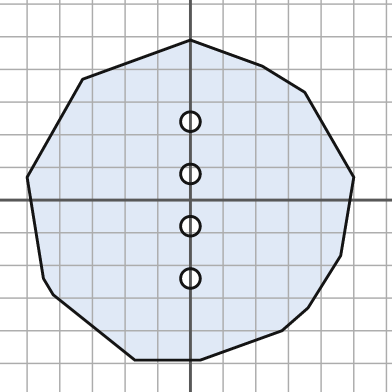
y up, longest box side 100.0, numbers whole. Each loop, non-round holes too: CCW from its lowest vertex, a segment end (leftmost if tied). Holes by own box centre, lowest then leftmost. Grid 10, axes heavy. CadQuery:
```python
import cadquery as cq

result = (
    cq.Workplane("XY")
    .moveTo(-17.0, -49.0)
    .lineTo(3.0, -49.0)
    .lineTo(28.0, -40.0)
    .lineTo(36.0, -33.0)
    .lineTo(46.0, -17.0)
    .lineTo(50.0, 7.0)
    .lineTo(35.0, 33.0)
    .lineTo(22.0, 41.0)
    .lineTo(0.0, 49.0)
    .lineTo(-33.0, 37.0)
    .lineTo(-50.0, 7.0)
    .lineTo(-45.0, -24.0)
    .lineTo(-42.0, -29.0)
    .close()
    .moveTo(0.0, -24.0)
    .circle(3.0)
    .moveTo(0.0, -8.0)
    .circle(3.0)
    .moveTo(0.0, 8.0)
    .circle(3.0)
    .moveTo(0.0, 24.0)
    .circle(3.0)
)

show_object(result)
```